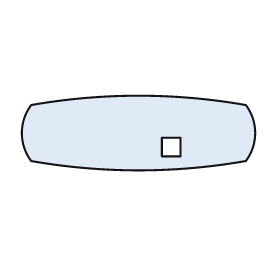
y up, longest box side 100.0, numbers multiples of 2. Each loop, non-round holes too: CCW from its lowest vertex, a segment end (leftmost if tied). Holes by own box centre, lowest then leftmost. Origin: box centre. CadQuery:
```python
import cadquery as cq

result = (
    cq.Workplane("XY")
    .moveTo(-46.0, -12.0)
    .threePointArc((0.0, -16.0), (46.0, -12.0))
    .threePointArc((50.0, 0.0), (46.0, 12.0))
    .threePointArc((0.0, 16.0), (-46.0, 12.0))
    .threePointArc((-50.0, 0.0), (-46.0, -12.0))
    .close()
    .moveTo(10.0, -10.0)
    .lineTo(18.0, -10.0)
    .lineTo(18.0, -2.0)
    .lineTo(10.0, -2.0)
    .close()
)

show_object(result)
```